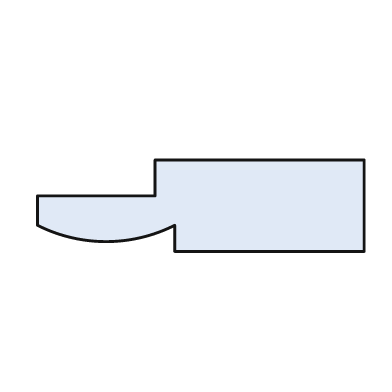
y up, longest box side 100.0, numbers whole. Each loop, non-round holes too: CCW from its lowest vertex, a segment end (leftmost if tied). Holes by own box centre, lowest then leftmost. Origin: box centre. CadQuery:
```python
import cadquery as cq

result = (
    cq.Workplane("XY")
    .moveTo(-8.0, -14.0)
    .lineTo(50.0, -14.0)
    .lineTo(50.0, 14.0)
    .lineTo(-14.0, 14.0)
    .lineTo(-14.0, 3.0)
    .lineTo(-50.0, 3.0)
    .lineTo(-50.0, -6.0)
    .threePointArc((-29.0, -11.0), (-8.0, -6.0))
    .close()
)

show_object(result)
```